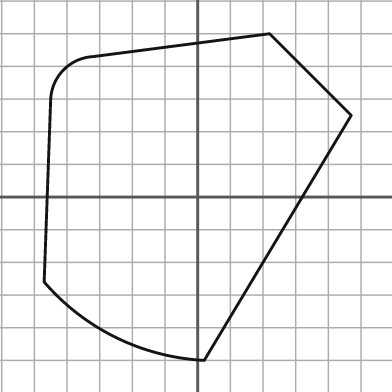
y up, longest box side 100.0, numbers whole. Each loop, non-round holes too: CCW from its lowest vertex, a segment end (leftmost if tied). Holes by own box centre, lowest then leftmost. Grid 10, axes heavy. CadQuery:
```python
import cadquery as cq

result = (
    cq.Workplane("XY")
    .moveTo(2.0, -50.0)
    .lineTo(47.0, 25.0)
    .lineTo(22.0, 50.0)
    .lineTo(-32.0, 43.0)
    .threePointArc((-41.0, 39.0), (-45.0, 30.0))
    .lineTo(-47.0, -26.0)
    .threePointArc((-25.0, -43.0), (2.0, -50.0))
    .close()
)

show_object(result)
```